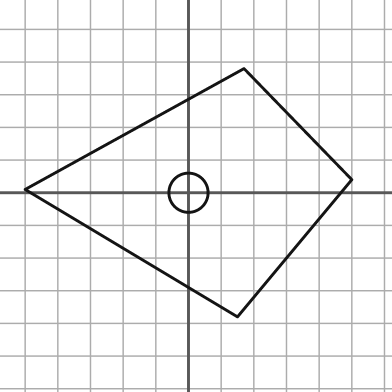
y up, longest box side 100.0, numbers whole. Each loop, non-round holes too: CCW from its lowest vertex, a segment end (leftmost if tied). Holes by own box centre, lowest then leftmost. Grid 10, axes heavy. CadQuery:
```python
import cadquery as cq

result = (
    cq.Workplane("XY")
    .moveTo(15.0, -38.0)
    .lineTo(50.0, 4.0)
    .lineTo(17.0, 38.0)
    .lineTo(-50.0, 1.0)
    .close()
    .moveTo(0.0, 0.0)
    .circle(6.0)
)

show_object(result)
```